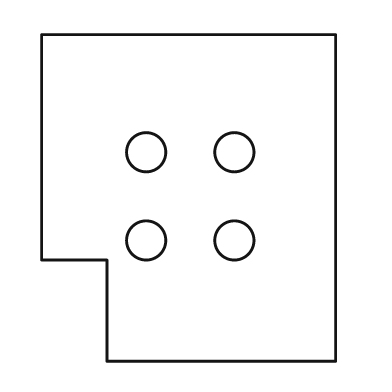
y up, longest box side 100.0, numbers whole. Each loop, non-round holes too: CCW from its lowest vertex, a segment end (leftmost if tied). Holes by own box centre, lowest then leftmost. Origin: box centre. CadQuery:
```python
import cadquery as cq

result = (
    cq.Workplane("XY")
    .moveTo(-25.0, -50.0)
    .lineTo(45.0, -50.0)
    .lineTo(45.0, 50.0)
    .lineTo(-45.0, 50.0)
    .lineTo(-45.0, -19.0)
    .lineTo(-25.0, -19.0)
    .close()
    .moveTo(-13.0, -13.0)
    .circle(6.0)
    .moveTo(14.0, -13.0)
    .circle(6.0)
    .moveTo(-13.0, 14.0)
    .circle(6.0)
    .moveTo(14.0, 14.0)
    .circle(6.0)
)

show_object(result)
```